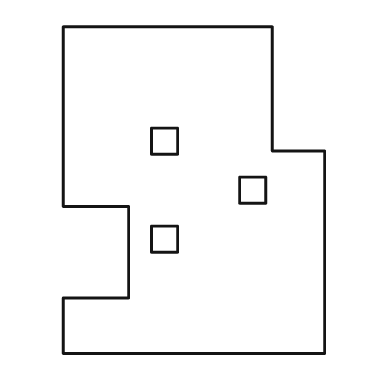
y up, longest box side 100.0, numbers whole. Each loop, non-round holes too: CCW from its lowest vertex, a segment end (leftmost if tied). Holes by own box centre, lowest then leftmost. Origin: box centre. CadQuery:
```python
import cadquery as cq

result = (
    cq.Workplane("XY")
    .moveTo(-40.0, -50.0)
    .lineTo(40.0, -50.0)
    .lineTo(40.0, 12.0)
    .lineTo(24.0, 12.0)
    .lineTo(24.0, 50.0)
    .lineTo(-40.0, 50.0)
    .lineTo(-40.0, -5.0)
    .lineTo(-20.0, -5.0)
    .lineTo(-20.0, -33.0)
    .lineTo(-40.0, -33.0)
    .close()
    .moveTo(-13.0, -19.0)
    .lineTo(-5.0, -19.0)
    .lineTo(-5.0, -11.0)
    .lineTo(-13.0, -11.0)
    .close()
    .moveTo(14.0, -4.0)
    .lineTo(22.0, -4.0)
    .lineTo(22.0, 4.0)
    .lineTo(14.0, 4.0)
    .close()
    .moveTo(-13.0, 11.0)
    .lineTo(-5.0, 11.0)
    .lineTo(-5.0, 19.0)
    .lineTo(-13.0, 19.0)
    .close()
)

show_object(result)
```